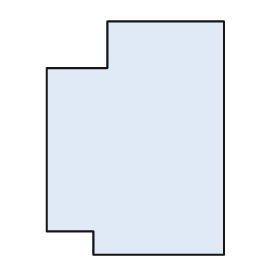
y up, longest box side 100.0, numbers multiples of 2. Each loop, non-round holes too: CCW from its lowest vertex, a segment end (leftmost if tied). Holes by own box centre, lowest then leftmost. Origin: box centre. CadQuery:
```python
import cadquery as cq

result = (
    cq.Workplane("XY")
    .moveTo(-18.0, -50.0)
    .lineTo(38.0, -50.0)
    .lineTo(38.0, 50.0)
    .lineTo(-12.0, 50.0)
    .lineTo(-12.0, 30.0)
    .lineTo(-38.0, 30.0)
    .lineTo(-38.0, -40.0)
    .lineTo(-18.0, -40.0)
    .close()
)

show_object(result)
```